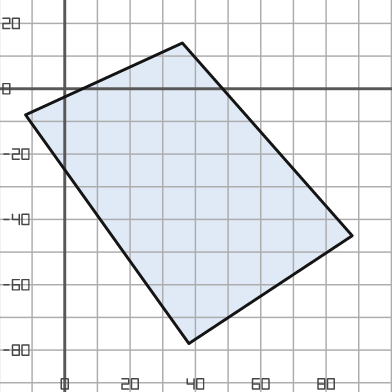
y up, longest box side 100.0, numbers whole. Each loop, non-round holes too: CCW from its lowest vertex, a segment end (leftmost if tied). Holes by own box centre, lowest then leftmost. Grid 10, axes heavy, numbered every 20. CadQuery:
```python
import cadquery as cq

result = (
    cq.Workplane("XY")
    .moveTo(38.0, -78.0)
    .lineTo(88.0, -45.0)
    .lineTo(36.0, 14.0)
    .lineTo(-12.0, -8.0)
    .close()
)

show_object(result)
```